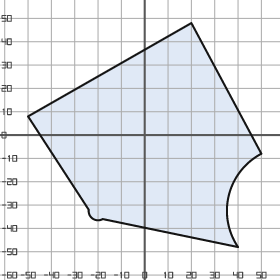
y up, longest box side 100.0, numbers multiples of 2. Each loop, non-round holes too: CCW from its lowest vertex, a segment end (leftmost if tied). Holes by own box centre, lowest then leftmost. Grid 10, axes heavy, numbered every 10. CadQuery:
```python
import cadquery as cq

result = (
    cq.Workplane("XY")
    .moveTo(40.0, -48.0)
    .threePointArc((36.0, -26.0), (50.0, -8.0))
    .lineTo(20.0, 48.0)
    .lineTo(-50.0, 8.0)
    .lineTo(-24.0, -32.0)
    .threePointArc((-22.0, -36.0), (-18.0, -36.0))
    .close()
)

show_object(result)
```